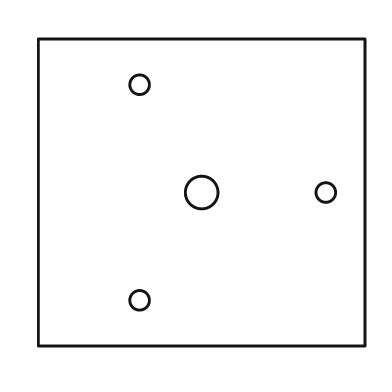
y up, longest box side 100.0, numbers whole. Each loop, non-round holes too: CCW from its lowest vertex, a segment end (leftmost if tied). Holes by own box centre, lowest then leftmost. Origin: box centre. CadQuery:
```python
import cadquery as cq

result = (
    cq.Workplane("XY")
    .moveTo(-50.0, -47.0)
    .lineTo(50.0, -47.0)
    .lineTo(50.0, 47.0)
    .lineTo(-50.0, 47.0)
    .close()
    .moveTo(-19.0, -33.0)
    .circle(3.0)
    .moveTo(0.0, 0.0)
    .circle(5.0)
    .moveTo(38.0, 0.0)
    .circle(3.0)
    .moveTo(-19.0, 33.0)
    .circle(3.0)
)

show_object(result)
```